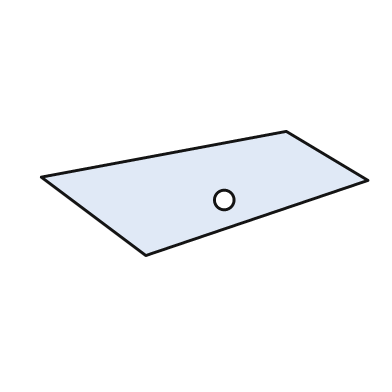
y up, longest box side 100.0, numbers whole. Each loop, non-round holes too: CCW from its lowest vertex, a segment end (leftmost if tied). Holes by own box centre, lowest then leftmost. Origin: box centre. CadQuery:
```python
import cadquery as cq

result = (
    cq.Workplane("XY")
    .moveTo(-18.0, -19.0)
    .lineTo(50.0, 4.0)
    .lineTo(25.0, 19.0)
    .lineTo(-50.0, 5.0)
    .close()
    .moveTo(6.0, -2.0)
    .circle(3.0)
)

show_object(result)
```